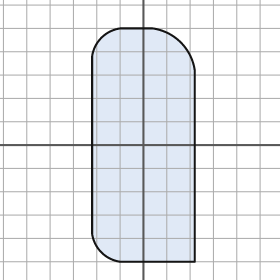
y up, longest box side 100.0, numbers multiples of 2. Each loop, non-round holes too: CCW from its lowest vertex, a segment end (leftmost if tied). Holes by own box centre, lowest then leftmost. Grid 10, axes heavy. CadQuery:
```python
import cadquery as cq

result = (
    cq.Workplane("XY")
    .moveTo(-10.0, -50.0)
    .lineTo(22.0, -50.0)
    .lineTo(22.0, 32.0)
    .threePointArc((16.0, 44.0), (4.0, 50.0))
    .lineTo(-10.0, 50.0)
    .threePointArc((-18.0, 46.0), (-22.0, 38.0))
    .lineTo(-22.0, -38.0)
    .threePointArc((-18.0, -46.0), (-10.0, -50.0))
    .close()
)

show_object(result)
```